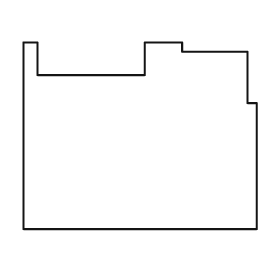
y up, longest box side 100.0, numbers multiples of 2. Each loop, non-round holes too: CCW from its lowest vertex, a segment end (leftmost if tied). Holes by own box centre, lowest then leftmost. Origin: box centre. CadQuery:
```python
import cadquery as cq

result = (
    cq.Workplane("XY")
    .moveTo(-50.0, -40.0)
    .lineTo(50.0, -40.0)
    .lineTo(50.0, 14.0)
    .lineTo(46.0, 14.0)
    .lineTo(46.0, 36.0)
    .lineTo(18.0, 36.0)
    .lineTo(18.0, 40.0)
    .lineTo(2.0, 40.0)
    .lineTo(2.0, 26.0)
    .lineTo(-44.0, 26.0)
    .lineTo(-44.0, 40.0)
    .lineTo(-50.0, 40.0)
    .close()
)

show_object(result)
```